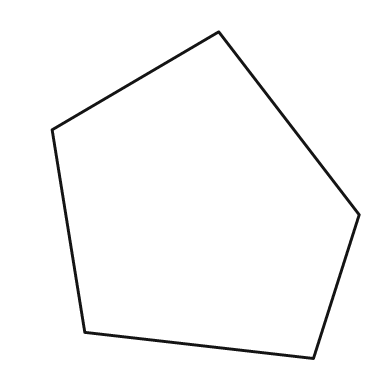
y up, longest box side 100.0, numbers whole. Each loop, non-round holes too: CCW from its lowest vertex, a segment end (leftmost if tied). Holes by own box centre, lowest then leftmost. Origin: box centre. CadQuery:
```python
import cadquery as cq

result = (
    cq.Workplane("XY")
    .moveTo(33.0, -50.0)
    .lineTo(47.0, -6.0)
    .lineTo(4.0, 50.0)
    .lineTo(-47.0, 20.0)
    .lineTo(-37.0, -42.0)
    .close()
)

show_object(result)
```